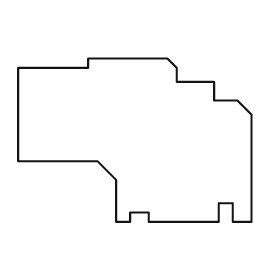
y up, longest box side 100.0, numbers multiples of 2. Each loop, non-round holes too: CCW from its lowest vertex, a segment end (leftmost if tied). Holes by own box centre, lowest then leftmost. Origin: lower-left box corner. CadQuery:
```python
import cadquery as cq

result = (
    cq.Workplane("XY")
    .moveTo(42.0, 0.0)
    .lineTo(48.0, 0.0)
    .lineTo(48.0, 4.0)
    .lineTo(56.0, 4.0)
    .lineTo(56.0, 0.0)
    .lineTo(86.0, 0.0)
    .lineTo(86.0, 8.0)
    .lineTo(92.0, 8.0)
    .lineTo(92.0, 0.0)
    .lineTo(100.0, 0.0)
    .lineTo(100.0, 46.0)
    .lineTo(94.0, 52.0)
    .lineTo(84.0, 52.0)
    .lineTo(84.0, 60.0)
    .lineTo(68.0, 60.0)
    .lineTo(68.0, 66.0)
    .lineTo(64.0, 70.0)
    .lineTo(30.0, 70.0)
    .lineTo(30.0, 66.0)
    .lineTo(0.0, 66.0)
    .lineTo(0.0, 26.0)
    .lineTo(34.0, 26.0)
    .lineTo(42.0, 18.0)
    .close()
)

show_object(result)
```